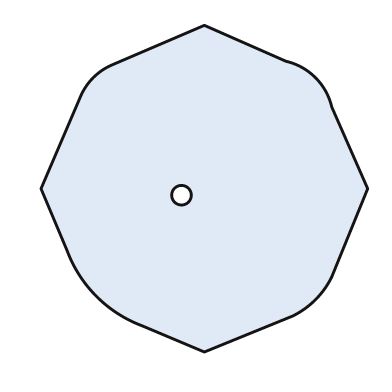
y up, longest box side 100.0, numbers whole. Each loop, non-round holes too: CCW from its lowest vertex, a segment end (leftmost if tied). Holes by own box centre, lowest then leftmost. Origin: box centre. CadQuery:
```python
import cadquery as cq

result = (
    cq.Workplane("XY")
    .moveTo(0.0, -50.0)
    .lineTo(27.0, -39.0)
    .threePointArc((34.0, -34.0), (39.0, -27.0))
    .lineTo(50.0, 0.0)
    .lineTo(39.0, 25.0)
    .threePointArc((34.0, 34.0), (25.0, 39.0))
    .lineTo(0.0, 50.0)
    .lineTo(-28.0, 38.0)
    .threePointArc((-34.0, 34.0), (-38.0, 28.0))
    .lineTo(-50.0, 0.0)
    .lineTo(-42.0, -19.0)
    .threePointArc((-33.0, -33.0), (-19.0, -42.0))
    .close()
    .moveTo(-7.0, -2.0)
    .circle(3.0)
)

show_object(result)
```